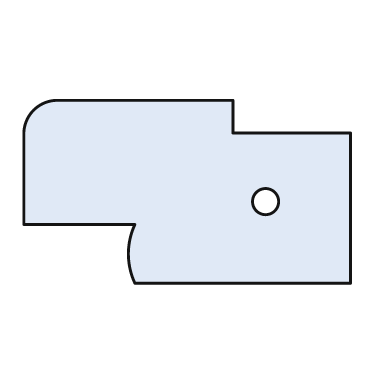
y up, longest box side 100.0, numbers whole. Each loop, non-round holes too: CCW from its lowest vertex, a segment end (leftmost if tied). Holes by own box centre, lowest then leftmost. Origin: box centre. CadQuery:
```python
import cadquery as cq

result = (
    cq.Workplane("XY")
    .moveTo(-16.0, -28.0)
    .lineTo(50.0, -28.0)
    .lineTo(50.0, 18.0)
    .lineTo(14.0, 18.0)
    .lineTo(14.0, 28.0)
    .lineTo(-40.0, 28.0)
    .threePointArc((-47.0, 25.0), (-50.0, 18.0))
    .lineTo(-50.0, -10.0)
    .lineTo(-16.0, -10.0)
    .threePointArc((-18.0, -19.0), (-16.0, -28.0))
    .close()
    .moveTo(24.0, -3.0)
    .circle(4.0)
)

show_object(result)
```